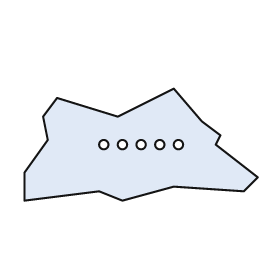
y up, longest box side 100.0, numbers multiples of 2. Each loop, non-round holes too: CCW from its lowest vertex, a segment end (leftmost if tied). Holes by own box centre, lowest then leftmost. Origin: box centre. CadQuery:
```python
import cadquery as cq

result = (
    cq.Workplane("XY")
    .moveTo(-50.0, -24.0)
    .lineTo(-18.0, -20.0)
    .lineTo(-8.0, -24.0)
    .lineTo(14.0, -18.0)
    .lineTo(44.0, -20.0)
    .lineTo(50.0, -14.0)
    .lineTo(32.0, 0.0)
    .lineTo(34.0, 4.0)
    .lineTo(26.0, 10.0)
    .lineTo(14.0, 24.0)
    .lineTo(-10.0, 12.0)
    .lineTo(-36.0, 20.0)
    .lineTo(-42.0, 12.0)
    .lineTo(-40.0, 2.0)
    .lineTo(-50.0, -12.0)
    .close()
    .moveTo(-16.0, 0.0)
    .circle(2.0)
    .moveTo(-8.0, 0.0)
    .circle(2.0)
    .moveTo(0.0, 0.0)
    .circle(2.0)
    .moveTo(8.0, 0.0)
    .circle(2.0)
    .moveTo(16.0, 0.0)
    .circle(2.0)
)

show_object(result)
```